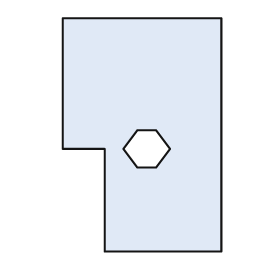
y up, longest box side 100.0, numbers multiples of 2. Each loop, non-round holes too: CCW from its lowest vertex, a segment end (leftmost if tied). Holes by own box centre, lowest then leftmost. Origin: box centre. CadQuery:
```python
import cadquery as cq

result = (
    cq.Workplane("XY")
    .moveTo(-16.0, -50.0)
    .lineTo(34.0, -50.0)
    .lineTo(34.0, 50.0)
    .lineTo(-34.0, 50.0)
    .lineTo(-34.0, -6.0)
    .lineTo(-16.0, -6.0)
    .close()
    .moveTo(-2.0, -14.0)
    .lineTo(6.0, -14.0)
    .lineTo(12.0, -6.0)
    .lineTo(6.0, 2.0)
    .lineTo(-2.0, 2.0)
    .lineTo(-8.0, -6.0)
    .close()
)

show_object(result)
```